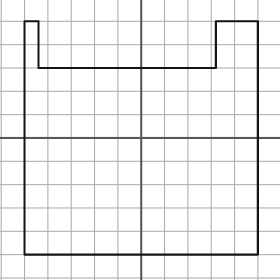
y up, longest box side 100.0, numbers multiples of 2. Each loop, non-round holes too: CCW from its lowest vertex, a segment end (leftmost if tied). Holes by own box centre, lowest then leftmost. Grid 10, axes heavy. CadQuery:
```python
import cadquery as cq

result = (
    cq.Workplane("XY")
    .moveTo(-50.0, -50.0)
    .lineTo(50.0, -50.0)
    .lineTo(50.0, 50.0)
    .lineTo(32.0, 50.0)
    .lineTo(32.0, 30.0)
    .lineTo(-44.0, 30.0)
    .lineTo(-44.0, 50.0)
    .lineTo(-50.0, 50.0)
    .close()
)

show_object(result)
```